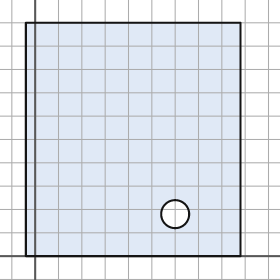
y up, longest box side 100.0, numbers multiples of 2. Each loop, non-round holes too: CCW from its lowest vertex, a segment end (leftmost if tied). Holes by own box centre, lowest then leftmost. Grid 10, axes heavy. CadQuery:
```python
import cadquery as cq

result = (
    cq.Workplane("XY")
    .moveTo(-4.0, 0.0)
    .lineTo(88.0, 0.0)
    .lineTo(88.0, 100.0)
    .lineTo(-4.0, 100.0)
    .close()
    .moveTo(60.0, 18.0)
    .circle(6.0)
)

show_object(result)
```